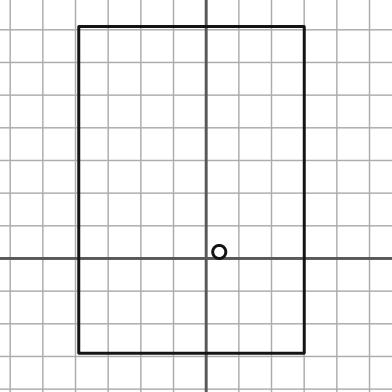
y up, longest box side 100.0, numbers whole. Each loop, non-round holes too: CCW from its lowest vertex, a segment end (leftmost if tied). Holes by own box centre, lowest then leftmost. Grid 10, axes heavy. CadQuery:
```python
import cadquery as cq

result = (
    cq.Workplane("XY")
    .moveTo(-39.0, -29.0)
    .lineTo(30.0, -29.0)
    .lineTo(30.0, 71.0)
    .lineTo(-39.0, 71.0)
    .close()
    .moveTo(4.0, 2.0)
    .circle(2.0)
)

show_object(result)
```